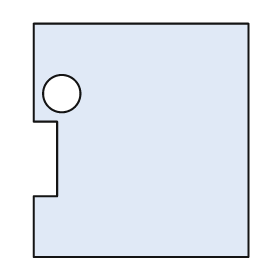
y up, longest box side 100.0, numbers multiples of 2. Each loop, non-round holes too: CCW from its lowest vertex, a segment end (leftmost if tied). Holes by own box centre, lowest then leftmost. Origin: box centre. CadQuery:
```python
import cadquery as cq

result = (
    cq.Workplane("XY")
    .moveTo(-46.0, -50.0)
    .lineTo(46.0, -50.0)
    .lineTo(46.0, 50.0)
    .lineTo(-46.0, 50.0)
    .lineTo(-46.0, 8.0)
    .lineTo(-36.0, 8.0)
    .lineTo(-36.0, -24.0)
    .lineTo(-46.0, -24.0)
    .close()
    .moveTo(-34.0, 20.0)
    .circle(8.0)
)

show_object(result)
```